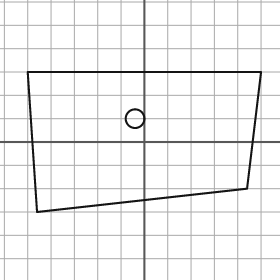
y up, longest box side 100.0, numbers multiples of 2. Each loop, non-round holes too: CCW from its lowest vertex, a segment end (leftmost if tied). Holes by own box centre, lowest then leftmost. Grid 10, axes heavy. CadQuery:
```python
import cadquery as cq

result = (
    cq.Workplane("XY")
    .moveTo(-46.0, -30.0)
    .lineTo(44.0, -20.0)
    .lineTo(50.0, 30.0)
    .lineTo(-50.0, 30.0)
    .close()
    .moveTo(-4.0, 10.0)
    .circle(4.0)
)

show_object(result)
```